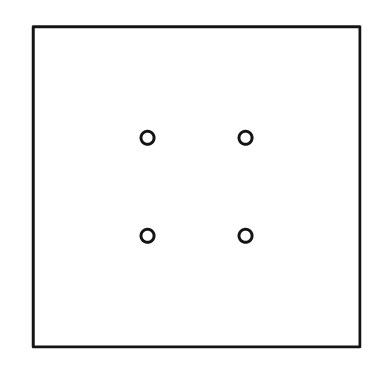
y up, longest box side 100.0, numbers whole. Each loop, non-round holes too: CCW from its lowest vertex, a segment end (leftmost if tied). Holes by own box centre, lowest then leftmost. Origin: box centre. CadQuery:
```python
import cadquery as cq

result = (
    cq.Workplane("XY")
    .moveTo(-50.0, -49.0)
    .lineTo(50.0, -49.0)
    .lineTo(50.0, 49.0)
    .lineTo(-50.0, 49.0)
    .close()
    .moveTo(-15.0, -15.0)
    .circle(2.0)
    .moveTo(15.0, -15.0)
    .circle(2.0)
    .moveTo(-15.0, 15.0)
    .circle(2.0)
    .moveTo(15.0, 15.0)
    .circle(2.0)
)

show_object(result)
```